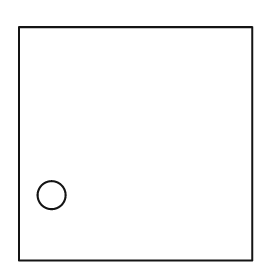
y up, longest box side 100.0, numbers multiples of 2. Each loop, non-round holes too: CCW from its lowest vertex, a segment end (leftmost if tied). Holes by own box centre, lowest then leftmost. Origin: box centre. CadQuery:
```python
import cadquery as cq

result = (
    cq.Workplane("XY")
    .moveTo(-50.0, -50.0)
    .lineTo(50.0, -50.0)
    .lineTo(50.0, 50.0)
    .lineTo(-50.0, 50.0)
    .close()
    .moveTo(-36.0, -22.0)
    .circle(6.0)
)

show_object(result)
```